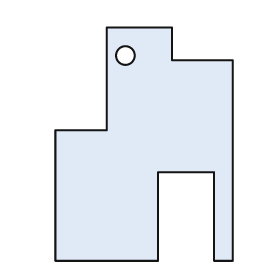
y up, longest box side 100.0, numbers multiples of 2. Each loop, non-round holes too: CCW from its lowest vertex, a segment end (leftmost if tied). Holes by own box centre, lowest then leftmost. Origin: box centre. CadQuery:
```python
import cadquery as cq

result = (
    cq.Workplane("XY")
    .moveTo(-38.0, -50.0)
    .lineTo(6.0, -50.0)
    .lineTo(6.0, -12.0)
    .lineTo(30.0, -12.0)
    .lineTo(30.0, -50.0)
    .lineTo(38.0, -50.0)
    .lineTo(38.0, 36.0)
    .lineTo(12.0, 36.0)
    .lineTo(12.0, 50.0)
    .lineTo(-16.0, 50.0)
    .lineTo(-16.0, 6.0)
    .lineTo(-38.0, 6.0)
    .close()
    .moveTo(-8.0, 38.0)
    .circle(4.0)
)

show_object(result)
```